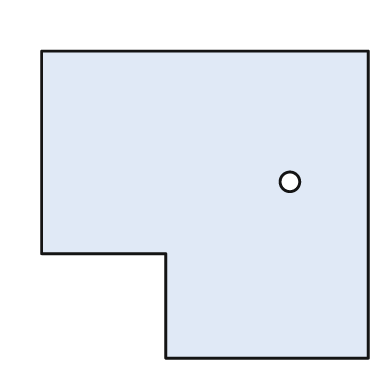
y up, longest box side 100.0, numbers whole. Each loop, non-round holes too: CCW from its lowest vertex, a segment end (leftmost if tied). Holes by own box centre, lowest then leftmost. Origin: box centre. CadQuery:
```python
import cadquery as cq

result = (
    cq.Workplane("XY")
    .moveTo(-12.0, -47.0)
    .lineTo(50.0, -47.0)
    .lineTo(50.0, 47.0)
    .lineTo(-50.0, 47.0)
    .lineTo(-50.0, -15.0)
    .lineTo(-12.0, -15.0)
    .close()
    .moveTo(26.0, 7.0)
    .circle(3.0)
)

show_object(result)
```